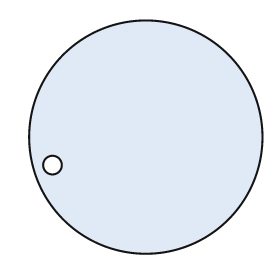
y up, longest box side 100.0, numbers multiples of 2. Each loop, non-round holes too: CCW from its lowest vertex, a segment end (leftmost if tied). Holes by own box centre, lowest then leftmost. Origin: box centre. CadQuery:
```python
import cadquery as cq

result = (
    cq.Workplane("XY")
    .moveTo(0.0, 0.0)
    .circle(50.0)
    .moveTo(-40.0, -12.0)
    .circle(4.0)
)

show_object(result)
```